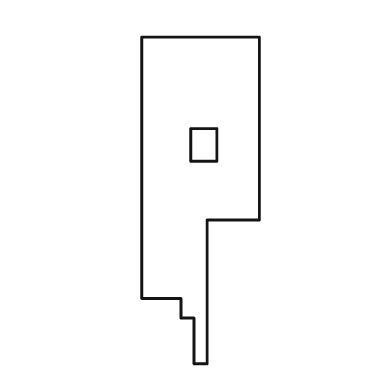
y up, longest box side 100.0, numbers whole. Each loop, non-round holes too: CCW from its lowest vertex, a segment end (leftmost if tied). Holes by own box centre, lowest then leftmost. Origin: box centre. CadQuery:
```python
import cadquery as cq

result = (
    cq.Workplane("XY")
    .moveTo(-2.0, -50.0)
    .lineTo(2.0, -50.0)
    .lineTo(2.0, -6.0)
    .lineTo(18.0, -6.0)
    .lineTo(18.0, 50.0)
    .lineTo(-18.0, 50.0)
    .lineTo(-18.0, -30.0)
    .lineTo(-6.0, -30.0)
    .lineTo(-6.0, -36.0)
    .lineTo(-2.0, -36.0)
    .close()
    .moveTo(-3.0, 12.0)
    .lineTo(5.0, 12.0)
    .lineTo(5.0, 22.0)
    .lineTo(-3.0, 22.0)
    .close()
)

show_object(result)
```